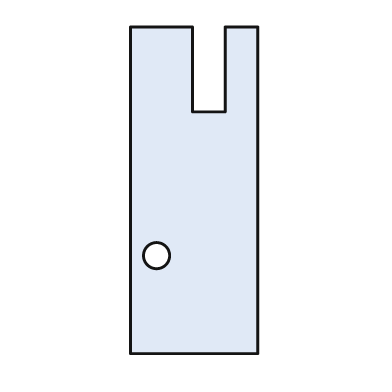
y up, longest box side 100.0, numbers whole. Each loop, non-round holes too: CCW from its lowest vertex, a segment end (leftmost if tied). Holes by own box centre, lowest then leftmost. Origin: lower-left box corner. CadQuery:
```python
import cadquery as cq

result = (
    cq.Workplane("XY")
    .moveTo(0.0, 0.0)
    .lineTo(39.0, 0.0)
    .lineTo(39.0, 100.0)
    .lineTo(29.0, 100.0)
    .lineTo(29.0, 74.0)
    .lineTo(19.0, 74.0)
    .lineTo(19.0, 100.0)
    .lineTo(0.0, 100.0)
    .close()
    .moveTo(8.0, 30.0)
    .circle(4.0)
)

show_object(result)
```